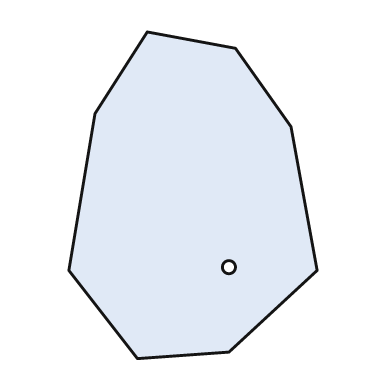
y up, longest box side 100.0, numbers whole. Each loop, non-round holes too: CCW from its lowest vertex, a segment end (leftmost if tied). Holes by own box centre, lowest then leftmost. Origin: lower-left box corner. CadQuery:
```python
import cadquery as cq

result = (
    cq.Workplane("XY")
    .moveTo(21.0, 0.0)
    .lineTo(49.0, 2.0)
    .lineTo(76.0, 27.0)
    .lineTo(68.0, 71.0)
    .lineTo(51.0, 95.0)
    .lineTo(24.0, 100.0)
    .lineTo(8.0, 75.0)
    .lineTo(0.0, 27.0)
    .close()
    .moveTo(49.0, 28.0)
    .circle(2.0)
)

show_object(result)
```